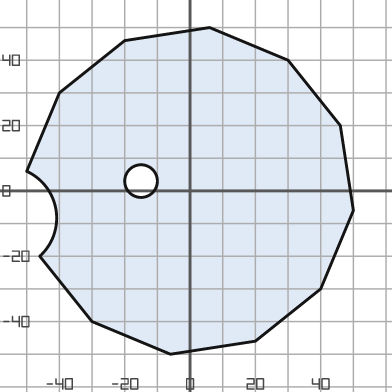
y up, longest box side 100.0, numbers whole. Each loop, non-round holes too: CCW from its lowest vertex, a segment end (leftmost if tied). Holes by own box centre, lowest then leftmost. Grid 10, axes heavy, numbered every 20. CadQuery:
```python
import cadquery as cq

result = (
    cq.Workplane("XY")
    .moveTo(-6.0, -50.0)
    .lineTo(20.0, -46.0)
    .lineTo(40.0, -30.0)
    .lineTo(50.0, -6.0)
    .lineTo(46.0, 20.0)
    .lineTo(30.0, 40.0)
    .lineTo(6.0, 50.0)
    .lineTo(-20.0, 46.0)
    .lineTo(-40.0, 30.0)
    .lineTo(-50.0, 6.0)
    .threePointArc((-41.0, -6.0), (-46.0, -20.0))
    .lineTo(-30.0, -40.0)
    .close()
    .moveTo(-15.0, 3.0)
    .circle(5.0)
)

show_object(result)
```